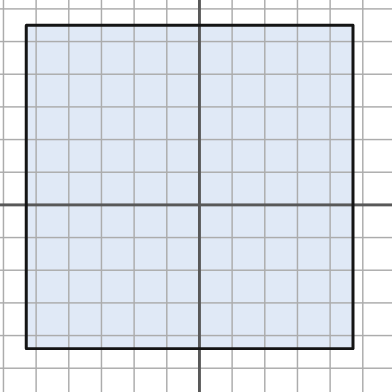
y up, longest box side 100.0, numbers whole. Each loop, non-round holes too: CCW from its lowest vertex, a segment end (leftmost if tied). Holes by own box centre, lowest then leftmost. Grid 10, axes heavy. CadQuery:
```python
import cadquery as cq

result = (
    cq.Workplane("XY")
    .moveTo(-53.0, -44.0)
    .lineTo(47.0, -44.0)
    .lineTo(47.0, 55.0)
    .lineTo(-53.0, 55.0)
    .close()
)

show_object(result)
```